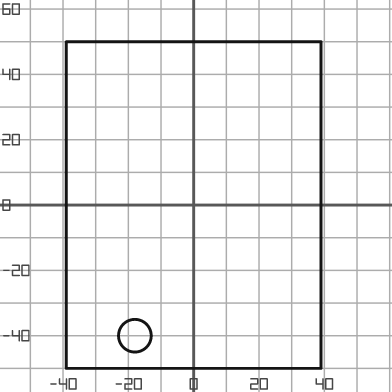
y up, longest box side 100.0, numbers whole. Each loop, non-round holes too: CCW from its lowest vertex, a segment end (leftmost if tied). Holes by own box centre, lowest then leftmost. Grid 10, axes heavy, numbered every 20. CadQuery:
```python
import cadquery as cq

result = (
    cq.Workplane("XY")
    .moveTo(-39.0, -50.0)
    .lineTo(39.0, -50.0)
    .lineTo(39.0, 50.0)
    .lineTo(-39.0, 50.0)
    .close()
    .moveTo(-18.0, -40.0)
    .circle(5.0)
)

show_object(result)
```